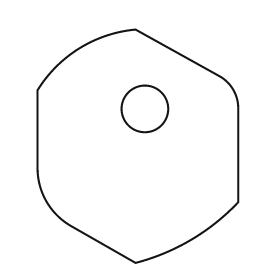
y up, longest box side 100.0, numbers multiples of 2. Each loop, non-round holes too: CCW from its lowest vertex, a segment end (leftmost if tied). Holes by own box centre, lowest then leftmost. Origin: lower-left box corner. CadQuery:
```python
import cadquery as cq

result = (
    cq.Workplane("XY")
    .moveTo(42.0, 0.0)
    .threePointArc((66.0, 10.0), (86.0, 26.0))
    .lineTo(86.0, 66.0)
    .threePointArc((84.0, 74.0), (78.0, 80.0))
    .lineTo(42.0, 100.0)
    .threePointArc((18.0, 92.0), (0.0, 74.0))
    .lineTo(0.0, 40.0)
    .threePointArc((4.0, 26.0), (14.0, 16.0))
    .close()
    .moveTo(46.0, 66.0)
    .circle(10.0)
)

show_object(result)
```